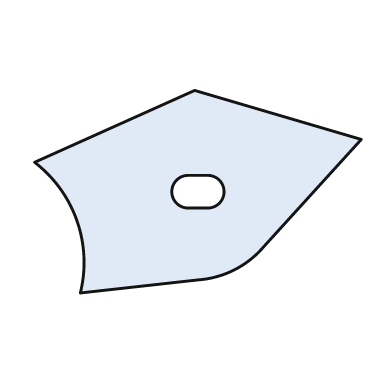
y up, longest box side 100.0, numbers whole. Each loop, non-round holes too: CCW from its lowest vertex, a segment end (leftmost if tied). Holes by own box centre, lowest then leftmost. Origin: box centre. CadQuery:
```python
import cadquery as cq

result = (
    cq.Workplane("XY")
    .moveTo(-36.0, -31.0)
    .lineTo(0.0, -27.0)
    .threePointArc((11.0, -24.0), (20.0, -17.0))
    .lineTo(50.0, 16.0)
    .lineTo(-1.0, 31.0)
    .lineTo(-50.0, 9.0)
    .threePointArc((-37.0, -9.0), (-36.0, -31.0))
    .close()
    .moveTo(-3.0, -5.0)
    .lineTo(3.0, -5.0)
    .threePointArc((8.0, 0.0), (3.0, 5.0))
    .lineTo(-3.0, 5.0)
    .threePointArc((-8.0, 0.0), (-3.0, -5.0))
    .close()
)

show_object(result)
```